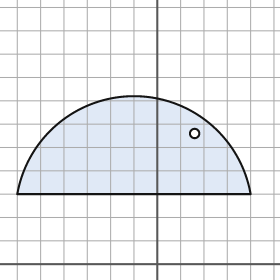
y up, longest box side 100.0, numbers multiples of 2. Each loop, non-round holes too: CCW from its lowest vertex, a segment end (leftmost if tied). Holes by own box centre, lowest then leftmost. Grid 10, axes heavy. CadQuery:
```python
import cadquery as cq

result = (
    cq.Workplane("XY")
    .moveTo(-60.0, 30.0)
    .lineTo(40.0, 30.0)
    .threePointArc((-10.0, 72.0), (-60.0, 30.0))
    .close()
    .moveTo(16.0, 56.0)
    .circle(2.0)
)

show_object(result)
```